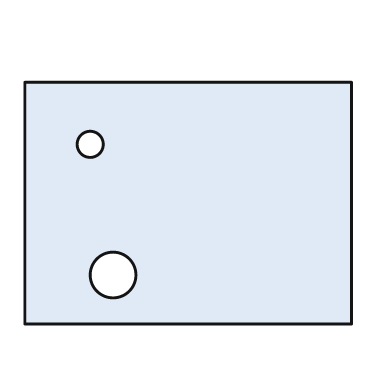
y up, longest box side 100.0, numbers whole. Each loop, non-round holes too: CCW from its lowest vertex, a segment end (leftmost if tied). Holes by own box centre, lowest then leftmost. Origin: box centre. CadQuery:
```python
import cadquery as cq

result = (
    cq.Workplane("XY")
    .moveTo(-50.0, -37.0)
    .lineTo(50.0, -37.0)
    .lineTo(50.0, 37.0)
    .lineTo(-50.0, 37.0)
    .close()
    .moveTo(-23.0, -22.0)
    .circle(7.0)
    .moveTo(-30.0, 18.0)
    .circle(4.0)
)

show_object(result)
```